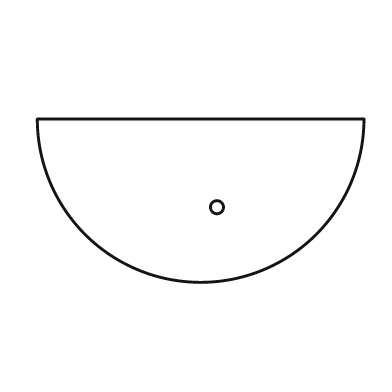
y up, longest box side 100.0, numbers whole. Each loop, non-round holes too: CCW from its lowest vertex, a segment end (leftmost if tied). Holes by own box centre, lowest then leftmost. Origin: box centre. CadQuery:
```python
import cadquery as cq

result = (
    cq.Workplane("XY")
    .moveTo(-50.0, 25.0)
    .threePointArc((0.0, -25.0), (50.0, 25.0))
    .close()
    .moveTo(5.0, -2.0)
    .circle(2.0)
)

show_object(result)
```